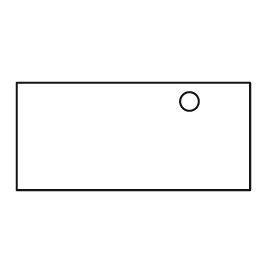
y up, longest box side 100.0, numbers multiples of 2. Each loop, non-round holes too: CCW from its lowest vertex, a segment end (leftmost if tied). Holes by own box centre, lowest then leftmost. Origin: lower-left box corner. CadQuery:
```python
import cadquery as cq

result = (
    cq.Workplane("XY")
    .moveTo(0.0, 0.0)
    .lineTo(100.0, 0.0)
    .lineTo(100.0, 46.0)
    .lineTo(0.0, 46.0)
    .close()
    .moveTo(74.0, 38.0)
    .circle(4.0)
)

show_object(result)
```